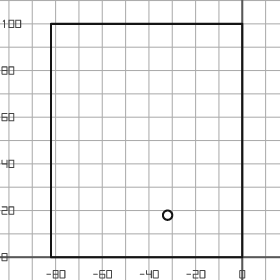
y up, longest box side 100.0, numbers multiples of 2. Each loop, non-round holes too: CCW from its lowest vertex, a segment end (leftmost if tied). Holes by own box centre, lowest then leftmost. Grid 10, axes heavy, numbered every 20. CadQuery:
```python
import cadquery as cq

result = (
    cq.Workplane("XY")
    .moveTo(-82.0, 0.0)
    .lineTo(0.0, 0.0)
    .lineTo(0.0, 100.0)
    .lineTo(-82.0, 100.0)
    .close()
    .moveTo(-32.0, 18.0)
    .circle(2.0)
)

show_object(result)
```